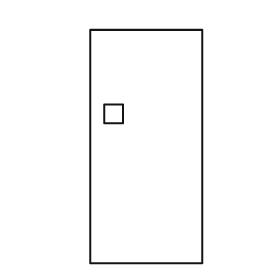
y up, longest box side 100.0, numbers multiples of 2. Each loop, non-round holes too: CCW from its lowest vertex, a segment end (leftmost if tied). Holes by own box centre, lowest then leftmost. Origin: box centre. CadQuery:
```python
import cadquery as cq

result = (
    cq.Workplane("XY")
    .moveTo(-24.0, -50.0)
    .lineTo(24.0, -50.0)
    .lineTo(24.0, 50.0)
    .lineTo(-24.0, 50.0)
    .close()
    .moveTo(-18.0, 10.0)
    .lineTo(-10.0, 10.0)
    .lineTo(-10.0, 18.0)
    .lineTo(-18.0, 18.0)
    .close()
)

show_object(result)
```